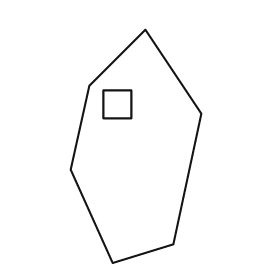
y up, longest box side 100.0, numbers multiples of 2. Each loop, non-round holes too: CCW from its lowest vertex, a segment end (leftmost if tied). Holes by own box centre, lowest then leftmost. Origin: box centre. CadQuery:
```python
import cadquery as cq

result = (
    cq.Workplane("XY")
    .moveTo(-10.0, -50.0)
    .lineTo(16.0, -42.0)
    .lineTo(28.0, 14.0)
    .lineTo(4.0, 50.0)
    .lineTo(-20.0, 26.0)
    .lineTo(-28.0, -10.0)
    .close()
    .moveTo(-14.0, 12.0)
    .lineTo(-2.0, 12.0)
    .lineTo(-2.0, 24.0)
    .lineTo(-14.0, 24.0)
    .close()
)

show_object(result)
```